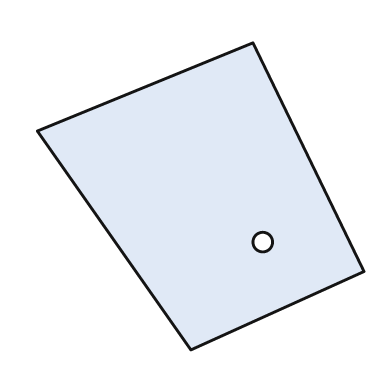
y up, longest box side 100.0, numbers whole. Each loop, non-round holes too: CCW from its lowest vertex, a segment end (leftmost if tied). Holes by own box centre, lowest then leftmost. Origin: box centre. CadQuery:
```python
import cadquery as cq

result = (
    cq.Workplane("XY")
    .moveTo(-3.0, -47.0)
    .lineTo(50.0, -23.0)
    .lineTo(16.0, 47.0)
    .lineTo(-50.0, 20.0)
    .close()
    .moveTo(19.0, -14.0)
    .circle(3.0)
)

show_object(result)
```